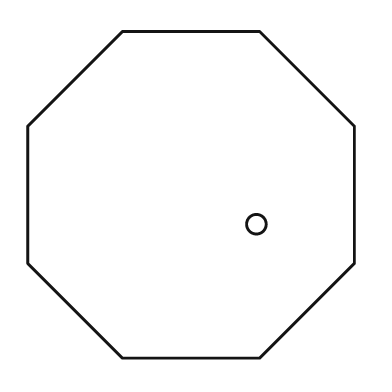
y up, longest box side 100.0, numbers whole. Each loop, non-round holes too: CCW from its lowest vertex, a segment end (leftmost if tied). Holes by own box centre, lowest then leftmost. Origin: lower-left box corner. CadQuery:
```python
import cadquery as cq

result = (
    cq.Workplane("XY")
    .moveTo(29.0, 0.0)
    .lineTo(71.0, 0.0)
    .lineTo(100.0, 29.0)
    .lineTo(100.0, 71.0)
    .lineTo(71.0, 100.0)
    .lineTo(29.0, 100.0)
    .lineTo(0.0, 71.0)
    .lineTo(0.0, 29.0)
    .close()
    .moveTo(70.0, 41.0)
    .circle(3.0)
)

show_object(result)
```